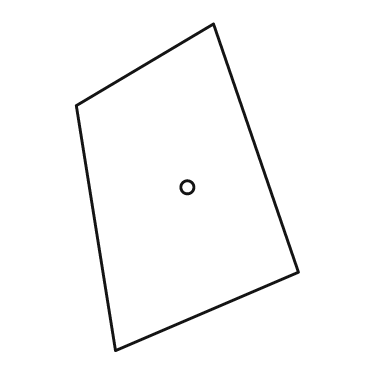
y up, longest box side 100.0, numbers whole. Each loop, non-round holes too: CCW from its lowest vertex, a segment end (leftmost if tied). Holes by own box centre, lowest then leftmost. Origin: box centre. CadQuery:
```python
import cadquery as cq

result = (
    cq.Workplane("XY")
    .moveTo(-22.0, -50.0)
    .lineTo(34.0, -26.0)
    .lineTo(8.0, 50.0)
    .lineTo(-34.0, 25.0)
    .close()
    .moveTo(0.0, 0.0)
    .circle(2.0)
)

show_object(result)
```